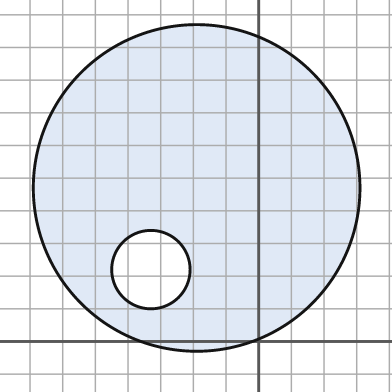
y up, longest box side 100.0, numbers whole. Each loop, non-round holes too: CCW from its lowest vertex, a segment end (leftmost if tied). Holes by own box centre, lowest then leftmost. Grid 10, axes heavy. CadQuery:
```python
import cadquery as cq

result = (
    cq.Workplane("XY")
    .moveTo(-19.0, 47.0)
    .circle(50.0)
    .moveTo(-33.0, 22.0)
    .circle(12.0)
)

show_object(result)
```